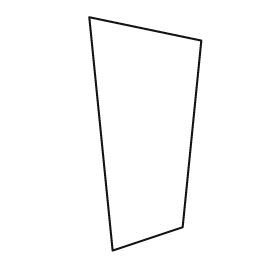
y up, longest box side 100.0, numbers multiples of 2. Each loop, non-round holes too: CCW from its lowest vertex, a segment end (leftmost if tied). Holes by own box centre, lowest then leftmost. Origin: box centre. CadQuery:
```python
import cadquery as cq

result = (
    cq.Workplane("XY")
    .moveTo(-14.0, -50.0)
    .lineTo(16.0, -40.0)
    .lineTo(24.0, 40.0)
    .lineTo(-24.0, 50.0)
    .close()
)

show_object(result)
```